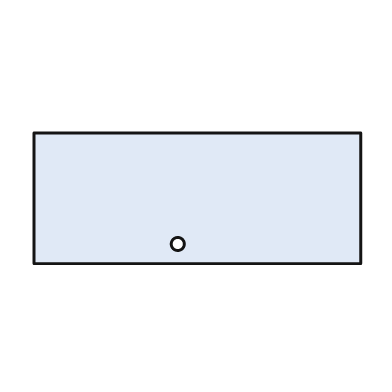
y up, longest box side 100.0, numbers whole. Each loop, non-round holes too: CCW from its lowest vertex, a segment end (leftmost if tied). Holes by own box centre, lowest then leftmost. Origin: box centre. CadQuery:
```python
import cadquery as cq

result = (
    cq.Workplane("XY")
    .moveTo(-50.0, -20.0)
    .lineTo(50.0, -20.0)
    .lineTo(50.0, 20.0)
    .lineTo(-50.0, 20.0)
    .close()
    .moveTo(-6.0, -14.0)
    .circle(2.0)
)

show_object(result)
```